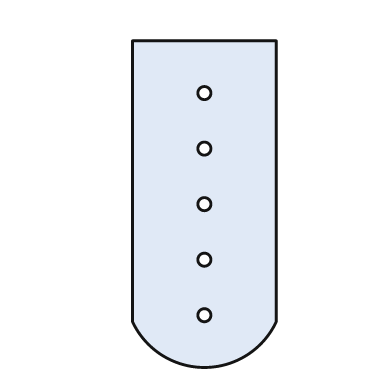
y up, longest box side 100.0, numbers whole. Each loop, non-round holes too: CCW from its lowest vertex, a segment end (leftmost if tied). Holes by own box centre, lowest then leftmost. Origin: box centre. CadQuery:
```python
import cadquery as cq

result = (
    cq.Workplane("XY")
    .moveTo(-22.0, -36.0)
    .threePointArc((0.0, -50.0), (22.0, -36.0))
    .lineTo(22.0, 50.0)
    .lineTo(-22.0, 50.0)
    .close()
    .moveTo(0.0, -34.0)
    .circle(2.0)
    .moveTo(0.0, -17.0)
    .circle(2.0)
    .moveTo(0.0, 0.0)
    .circle(2.0)
    .moveTo(0.0, 17.0)
    .circle(2.0)
    .moveTo(0.0, 34.0)
    .circle(2.0)
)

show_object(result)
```